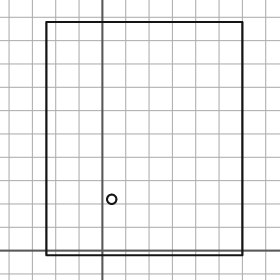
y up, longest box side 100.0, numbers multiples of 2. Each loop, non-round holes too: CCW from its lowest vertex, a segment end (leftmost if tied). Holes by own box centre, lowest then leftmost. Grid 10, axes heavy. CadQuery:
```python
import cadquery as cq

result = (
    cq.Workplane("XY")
    .moveTo(-24.0, -2.0)
    .lineTo(60.0, -2.0)
    .lineTo(60.0, 98.0)
    .lineTo(-24.0, 98.0)
    .close()
    .moveTo(4.0, 22.0)
    .circle(2.0)
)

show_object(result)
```